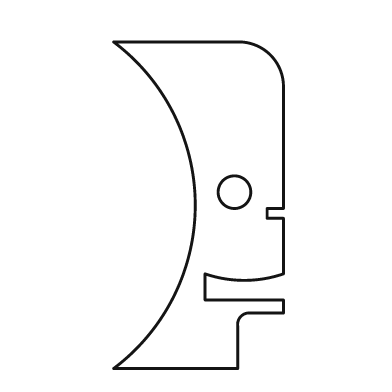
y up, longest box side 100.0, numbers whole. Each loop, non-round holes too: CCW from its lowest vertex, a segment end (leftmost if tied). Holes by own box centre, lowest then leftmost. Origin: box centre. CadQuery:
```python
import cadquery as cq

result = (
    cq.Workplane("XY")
    .moveTo(-26.0, -50.0)
    .lineTo(12.0, -50.0)
    .lineTo(12.0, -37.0)
    .threePointArc((13.0, -34.0), (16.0, -33.0))
    .lineTo(26.0, -33.0)
    .lineTo(26.0, -29.0)
    .lineTo(2.0, -29.0)
    .lineTo(2.0, -21.0)
    .threePointArc((14.0, -23.0), (26.0, -21.0))
    .lineTo(26.0, -4.0)
    .lineTo(21.0, -4.0)
    .lineTo(21.0, -1.0)
    .lineTo(26.0, -1.0)
    .lineTo(26.0, 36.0)
    .threePointArc((22.0, 46.0), (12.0, 50.0))
    .lineTo(-26.0, 50.0)
    .threePointArc((-1.0, 0.0), (-26.0, -50.0))
    .close()
    .moveTo(11.0, 4.0)
    .circle(5.0)
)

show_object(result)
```